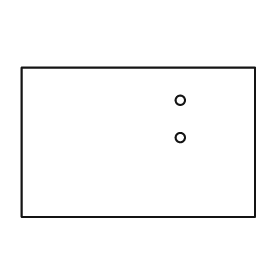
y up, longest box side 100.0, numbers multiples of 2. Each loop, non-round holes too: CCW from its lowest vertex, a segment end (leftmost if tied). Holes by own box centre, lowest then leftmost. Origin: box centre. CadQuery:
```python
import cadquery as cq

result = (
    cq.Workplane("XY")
    .moveTo(-50.0, -32.0)
    .lineTo(50.0, -32.0)
    .lineTo(50.0, 32.0)
    .lineTo(-50.0, 32.0)
    .close()
    .moveTo(18.0, 2.0)
    .circle(2.0)
    .moveTo(18.0, 18.0)
    .circle(2.0)
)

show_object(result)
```